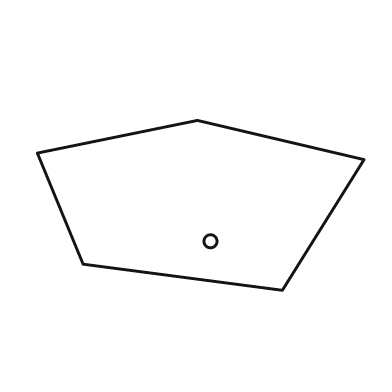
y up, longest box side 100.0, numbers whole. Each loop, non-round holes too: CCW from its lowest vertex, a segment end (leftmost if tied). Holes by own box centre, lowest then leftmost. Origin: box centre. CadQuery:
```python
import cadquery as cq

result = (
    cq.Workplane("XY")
    .moveTo(25.0, -26.0)
    .lineTo(50.0, 14.0)
    .lineTo(-1.0, 26.0)
    .lineTo(-50.0, 16.0)
    .lineTo(-36.0, -18.0)
    .close()
    .moveTo(3.0, -11.0)
    .circle(2.0)
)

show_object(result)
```